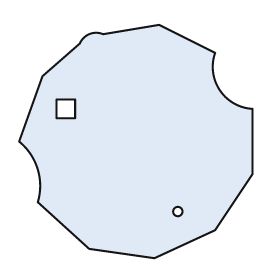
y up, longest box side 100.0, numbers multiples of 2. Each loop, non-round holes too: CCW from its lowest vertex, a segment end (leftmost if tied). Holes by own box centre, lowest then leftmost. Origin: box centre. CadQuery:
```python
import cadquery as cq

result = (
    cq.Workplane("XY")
    .moveTo(8.0, -50.0)
    .lineTo(34.0, -38.0)
    .lineTo(50.0, -14.0)
    .lineTo(50.0, 14.0)
    .threePointArc((36.0, 22.0), (34.0, 38.0))
    .lineTo(10.0, 50.0)
    .lineTo(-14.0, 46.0)
    .threePointArc((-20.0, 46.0), (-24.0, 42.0))
    .lineTo(-40.0, 28.0)
    .lineTo(-50.0, 0.0)
    .threePointArc((-42.0, -12.0), (-42.0, -26.0))
    .lineTo(-20.0, -46.0)
    .close()
    .moveTo(18.0, -30.0)
    .circle(2.0)
    .moveTo(-34.0, 10.0)
    .lineTo(-26.0, 10.0)
    .lineTo(-26.0, 18.0)
    .lineTo(-34.0, 18.0)
    .close()
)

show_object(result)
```